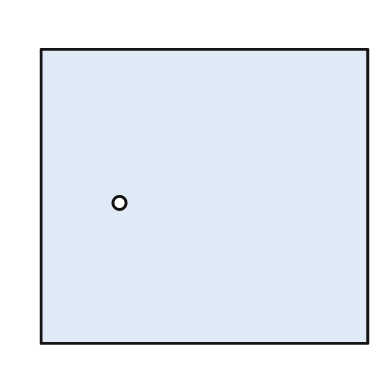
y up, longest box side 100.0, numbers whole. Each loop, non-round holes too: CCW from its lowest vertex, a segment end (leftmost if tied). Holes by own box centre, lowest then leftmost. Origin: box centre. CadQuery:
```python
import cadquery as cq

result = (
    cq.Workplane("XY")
    .moveTo(-50.0, -45.0)
    .lineTo(50.0, -45.0)
    .lineTo(50.0, 45.0)
    .lineTo(-50.0, 45.0)
    .close()
    .moveTo(-26.0, -2.0)
    .circle(2.0)
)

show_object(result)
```